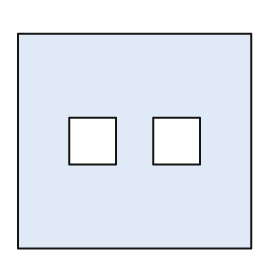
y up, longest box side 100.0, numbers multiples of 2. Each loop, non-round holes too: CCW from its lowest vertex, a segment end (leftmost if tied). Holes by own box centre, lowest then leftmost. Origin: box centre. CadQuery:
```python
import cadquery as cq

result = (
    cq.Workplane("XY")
    .moveTo(-50.0, -46.0)
    .lineTo(50.0, -46.0)
    .lineTo(50.0, 46.0)
    .lineTo(-50.0, 46.0)
    .close()
    .moveTo(-28.0, -10.0)
    .lineTo(-8.0, -10.0)
    .lineTo(-8.0, 10.0)
    .lineTo(-28.0, 10.0)
    .close()
    .moveTo(8.0, -10.0)
    .lineTo(28.0, -10.0)
    .lineTo(28.0, 10.0)
    .lineTo(8.0, 10.0)
    .close()
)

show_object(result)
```